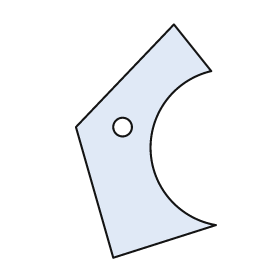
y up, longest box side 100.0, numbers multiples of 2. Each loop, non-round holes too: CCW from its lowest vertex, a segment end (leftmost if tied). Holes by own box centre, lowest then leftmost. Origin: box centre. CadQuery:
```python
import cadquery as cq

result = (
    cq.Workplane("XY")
    .moveTo(-14.0, -50.0)
    .lineTo(30.0, -36.0)
    .threePointArc((2.0, -4.0), (28.0, 30.0))
    .lineTo(12.0, 50.0)
    .lineTo(-30.0, 6.0)
    .close()
    .moveTo(-10.0, 6.0)
    .circle(4.0)
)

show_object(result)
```